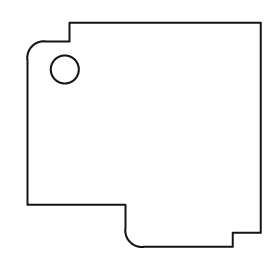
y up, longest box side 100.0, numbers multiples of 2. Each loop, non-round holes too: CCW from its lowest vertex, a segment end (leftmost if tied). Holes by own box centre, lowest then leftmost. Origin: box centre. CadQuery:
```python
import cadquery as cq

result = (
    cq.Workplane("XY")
    .moveTo(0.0, -48.0)
    .lineTo(38.0, -48.0)
    .lineTo(38.0, -42.0)
    .lineTo(50.0, -42.0)
    .lineTo(50.0, 48.0)
    .lineTo(-32.0, 48.0)
    .lineTo(-32.0, 40.0)
    .lineTo(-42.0, 40.0)
    .threePointArc((-48.0, 38.0), (-50.0, 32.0))
    .lineTo(-50.0, -30.0)
    .lineTo(-8.0, -30.0)
    .lineTo(-8.0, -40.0)
    .threePointArc((-6.0, -46.0), (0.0, -48.0))
    .close()
    .moveTo(-34.0, 28.0)
    .circle(6.0)
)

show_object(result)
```